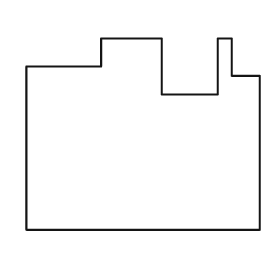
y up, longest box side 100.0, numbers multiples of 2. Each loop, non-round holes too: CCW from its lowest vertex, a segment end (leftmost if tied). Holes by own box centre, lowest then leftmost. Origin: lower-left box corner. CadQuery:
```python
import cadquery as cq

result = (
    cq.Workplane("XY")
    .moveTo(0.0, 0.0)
    .lineTo(100.0, 0.0)
    .lineTo(100.0, 66.0)
    .lineTo(88.0, 66.0)
    .lineTo(88.0, 82.0)
    .lineTo(82.0, 82.0)
    .lineTo(82.0, 58.0)
    .lineTo(58.0, 58.0)
    .lineTo(58.0, 82.0)
    .lineTo(32.0, 82.0)
    .lineTo(32.0, 70.0)
    .lineTo(0.0, 70.0)
    .close()
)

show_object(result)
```